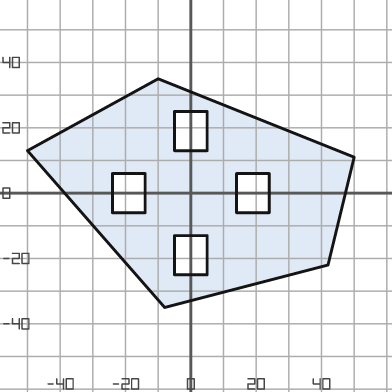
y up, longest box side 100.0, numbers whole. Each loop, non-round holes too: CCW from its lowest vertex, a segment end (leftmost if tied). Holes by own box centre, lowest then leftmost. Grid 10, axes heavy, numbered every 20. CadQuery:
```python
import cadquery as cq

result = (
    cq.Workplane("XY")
    .moveTo(-8.0, -35.0)
    .lineTo(42.0, -22.0)
    .lineTo(50.0, 11.0)
    .lineTo(-10.0, 35.0)
    .lineTo(-50.0, 13.0)
    .close()
    .moveTo(-5.0, -25.0)
    .lineTo(5.0, -25.0)
    .lineTo(5.0, -13.0)
    .lineTo(-5.0, -13.0)
    .close()
    .moveTo(-24.0, -6.0)
    .lineTo(-14.0, -6.0)
    .lineTo(-14.0, 6.0)
    .lineTo(-24.0, 6.0)
    .close()
    .moveTo(14.0, -6.0)
    .lineTo(24.0, -6.0)
    .lineTo(24.0, 6.0)
    .lineTo(14.0, 6.0)
    .close()
    .moveTo(-5.0, 13.0)
    .lineTo(5.0, 13.0)
    .lineTo(5.0, 25.0)
    .lineTo(-5.0, 25.0)
    .close()
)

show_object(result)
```